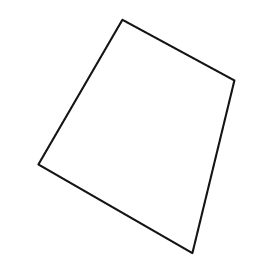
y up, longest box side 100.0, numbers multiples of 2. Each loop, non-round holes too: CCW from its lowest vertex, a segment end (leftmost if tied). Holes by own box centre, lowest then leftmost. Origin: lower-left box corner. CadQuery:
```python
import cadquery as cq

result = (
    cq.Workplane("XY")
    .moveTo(66.0, 0.0)
    .lineTo(84.0, 74.0)
    .lineTo(36.0, 100.0)
    .lineTo(0.0, 38.0)
    .close()
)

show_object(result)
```